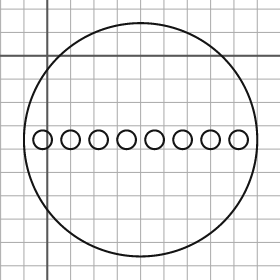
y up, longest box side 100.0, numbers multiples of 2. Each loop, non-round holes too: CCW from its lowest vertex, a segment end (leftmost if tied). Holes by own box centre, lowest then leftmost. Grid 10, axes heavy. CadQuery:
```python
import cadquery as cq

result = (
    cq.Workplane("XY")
    .moveTo(40.0, -36.0)
    .circle(50.0)
    .moveTo(-2.0, -36.0)
    .circle(4.0)
    .moveTo(10.0, -36.0)
    .circle(4.0)
    .moveTo(22.0, -36.0)
    .circle(4.0)
    .moveTo(34.0, -36.0)
    .circle(4.0)
    .moveTo(46.0, -36.0)
    .circle(4.0)
    .moveTo(58.0, -36.0)
    .circle(4.0)
    .moveTo(70.0, -36.0)
    .circle(4.0)
    .moveTo(82.0, -36.0)
    .circle(4.0)
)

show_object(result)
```